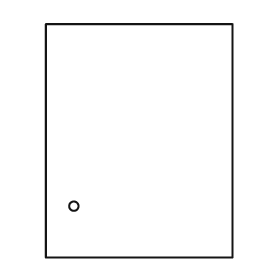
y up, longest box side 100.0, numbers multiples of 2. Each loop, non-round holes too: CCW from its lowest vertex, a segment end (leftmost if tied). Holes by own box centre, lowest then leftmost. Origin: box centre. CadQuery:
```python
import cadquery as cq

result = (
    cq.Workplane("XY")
    .moveTo(-40.0, -50.0)
    .lineTo(40.0, -50.0)
    .lineTo(40.0, 50.0)
    .lineTo(-40.0, 50.0)
    .close()
    .moveTo(-28.0, -28.0)
    .circle(2.0)
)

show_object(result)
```